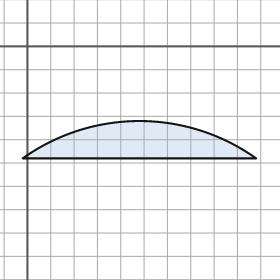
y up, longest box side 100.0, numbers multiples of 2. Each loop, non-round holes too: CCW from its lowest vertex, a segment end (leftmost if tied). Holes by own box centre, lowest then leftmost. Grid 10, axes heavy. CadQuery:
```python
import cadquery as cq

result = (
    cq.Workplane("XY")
    .moveTo(-2.0, -48.0)
    .lineTo(98.0, -48.0)
    .threePointArc((48.0, -32.0), (-2.0, -48.0))
    .close()
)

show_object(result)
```